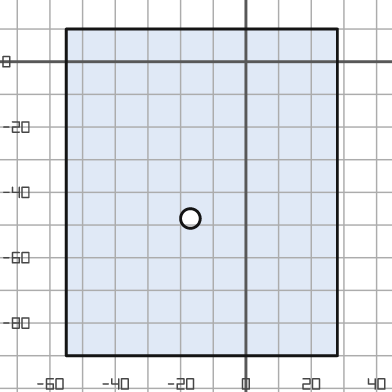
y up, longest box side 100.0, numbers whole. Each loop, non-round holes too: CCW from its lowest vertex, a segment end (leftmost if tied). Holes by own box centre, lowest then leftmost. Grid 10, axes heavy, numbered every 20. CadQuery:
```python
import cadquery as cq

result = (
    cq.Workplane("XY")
    .moveTo(-55.0, -90.0)
    .lineTo(28.0, -90.0)
    .lineTo(28.0, 10.0)
    .lineTo(-55.0, 10.0)
    .close()
    .moveTo(-17.0, -48.0)
    .circle(3.0)
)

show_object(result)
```